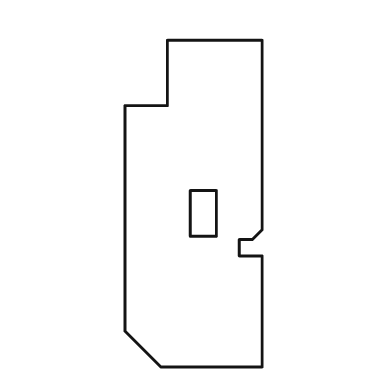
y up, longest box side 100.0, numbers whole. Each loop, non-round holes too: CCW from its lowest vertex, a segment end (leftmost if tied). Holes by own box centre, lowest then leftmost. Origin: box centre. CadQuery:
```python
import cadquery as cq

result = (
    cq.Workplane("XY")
    .moveTo(-10.0, -50.0)
    .lineTo(21.0, -50.0)
    .lineTo(21.0, -16.0)
    .lineTo(14.0, -16.0)
    .lineTo(14.0, -11.0)
    .lineTo(18.0, -11.0)
    .lineTo(21.0, -8.0)
    .lineTo(21.0, 50.0)
    .lineTo(-8.0, 50.0)
    .lineTo(-8.0, 30.0)
    .lineTo(-21.0, 30.0)
    .lineTo(-21.0, -39.0)
    .close()
    .moveTo(-1.0, -10.0)
    .lineTo(7.0, -10.0)
    .lineTo(7.0, 4.0)
    .lineTo(-1.0, 4.0)
    .close()
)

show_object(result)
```